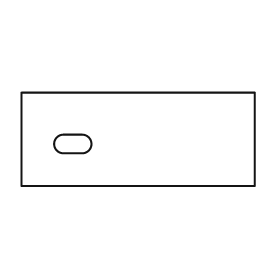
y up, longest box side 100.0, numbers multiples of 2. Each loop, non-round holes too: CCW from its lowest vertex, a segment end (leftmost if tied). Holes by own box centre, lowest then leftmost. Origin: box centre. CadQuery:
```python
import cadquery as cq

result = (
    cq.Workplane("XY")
    .moveTo(-50.0, -20.0)
    .lineTo(50.0, -20.0)
    .lineTo(50.0, 20.0)
    .lineTo(-50.0, 20.0)
    .close()
    .moveTo(-32.0, -6.0)
    .lineTo(-24.0, -6.0)
    .threePointArc((-20.0, -2.0), (-24.0, 2.0))
    .lineTo(-32.0, 2.0)
    .threePointArc((-36.0, -2.0), (-32.0, -6.0))
    .close()
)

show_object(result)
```